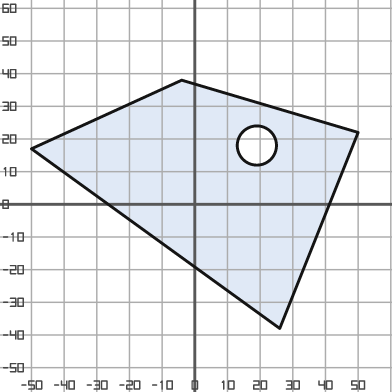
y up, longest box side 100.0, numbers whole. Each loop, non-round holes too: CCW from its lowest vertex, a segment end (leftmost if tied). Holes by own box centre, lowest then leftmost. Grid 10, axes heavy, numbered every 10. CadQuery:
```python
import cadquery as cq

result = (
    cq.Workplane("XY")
    .moveTo(26.0, -38.0)
    .lineTo(50.0, 22.0)
    .lineTo(-4.0, 38.0)
    .lineTo(-50.0, 17.0)
    .close()
    .moveTo(19.0, 18.0)
    .circle(6.0)
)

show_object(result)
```